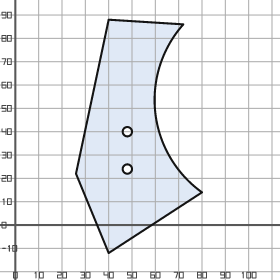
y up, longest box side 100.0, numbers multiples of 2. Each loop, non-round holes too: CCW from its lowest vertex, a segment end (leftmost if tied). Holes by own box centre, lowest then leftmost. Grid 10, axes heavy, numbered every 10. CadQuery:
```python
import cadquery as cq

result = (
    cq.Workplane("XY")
    .moveTo(40.0, -12.0)
    .lineTo(80.0, 14.0)
    .threePointArc((60.0, 48.0), (72.0, 86.0))
    .lineTo(40.0, 88.0)
    .lineTo(26.0, 22.0)
    .close()
    .moveTo(48.0, 24.0)
    .circle(2.0)
    .moveTo(48.0, 40.0)
    .circle(2.0)
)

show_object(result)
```